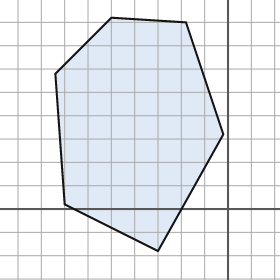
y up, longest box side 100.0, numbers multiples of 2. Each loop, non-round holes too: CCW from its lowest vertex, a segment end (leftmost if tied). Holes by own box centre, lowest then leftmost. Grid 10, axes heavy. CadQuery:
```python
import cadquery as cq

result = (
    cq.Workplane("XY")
    .moveTo(-30.0, -18.0)
    .lineTo(-2.0, 32.0)
    .lineTo(-18.0, 80.0)
    .lineTo(-50.0, 82.0)
    .lineTo(-74.0, 58.0)
    .lineTo(-70.0, 2.0)
    .close()
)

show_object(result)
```